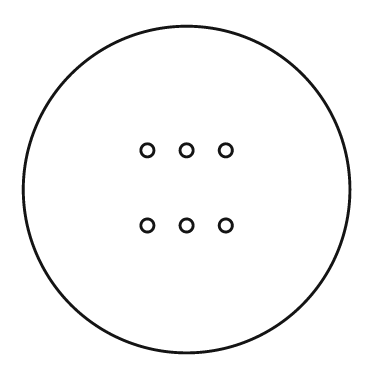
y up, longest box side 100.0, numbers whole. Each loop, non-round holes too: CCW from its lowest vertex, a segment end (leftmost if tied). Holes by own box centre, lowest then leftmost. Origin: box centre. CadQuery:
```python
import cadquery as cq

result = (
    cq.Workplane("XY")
    .moveTo(0.0, 0.0)
    .circle(50.0)
    .moveTo(-12.0, -11.0)
    .circle(2.0)
    .moveTo(0.0, -11.0)
    .circle(2.0)
    .moveTo(12.0, -11.0)
    .circle(2.0)
    .moveTo(-12.0, 12.0)
    .circle(2.0)
    .moveTo(0.0, 12.0)
    .circle(2.0)
    .moveTo(12.0, 12.0)
    .circle(2.0)
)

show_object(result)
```